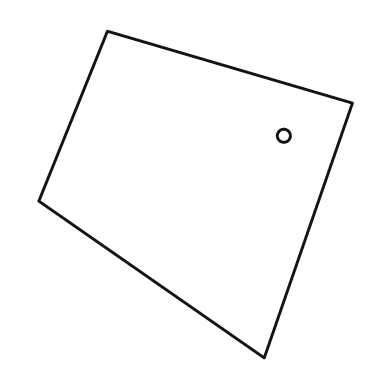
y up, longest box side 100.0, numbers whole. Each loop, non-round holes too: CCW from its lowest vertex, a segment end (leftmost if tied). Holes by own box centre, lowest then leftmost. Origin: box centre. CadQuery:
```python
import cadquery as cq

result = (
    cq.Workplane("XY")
    .moveTo(21.0, -50.0)
    .lineTo(48.0, 28.0)
    .lineTo(-27.0, 50.0)
    .lineTo(-48.0, -2.0)
    .close()
    .moveTo(27.0, 18.0)
    .circle(2.0)
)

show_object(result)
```